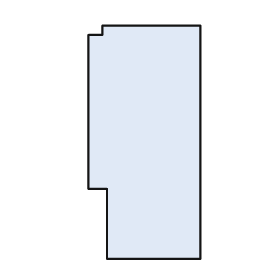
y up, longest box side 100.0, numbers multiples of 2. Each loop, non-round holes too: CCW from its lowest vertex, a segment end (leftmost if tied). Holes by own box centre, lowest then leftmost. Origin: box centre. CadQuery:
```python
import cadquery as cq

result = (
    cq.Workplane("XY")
    .moveTo(-16.0, -50.0)
    .lineTo(24.0, -50.0)
    .lineTo(24.0, 50.0)
    .lineTo(-18.0, 50.0)
    .lineTo(-18.0, 46.0)
    .lineTo(-24.0, 46.0)
    .lineTo(-24.0, -20.0)
    .lineTo(-16.0, -20.0)
    .close()
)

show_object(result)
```